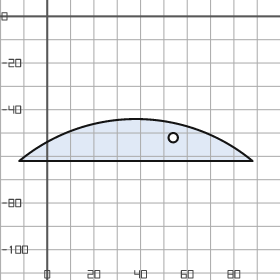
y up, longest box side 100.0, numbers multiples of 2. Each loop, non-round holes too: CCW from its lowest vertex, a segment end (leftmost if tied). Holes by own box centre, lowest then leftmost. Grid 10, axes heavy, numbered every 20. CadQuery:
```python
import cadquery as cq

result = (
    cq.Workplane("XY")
    .moveTo(-12.0, -62.0)
    .lineTo(88.0, -62.0)
    .threePointArc((38.0, -44.0), (-12.0, -62.0))
    .close()
    .moveTo(54.0, -52.0)
    .circle(2.0)
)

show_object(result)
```